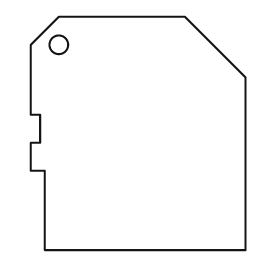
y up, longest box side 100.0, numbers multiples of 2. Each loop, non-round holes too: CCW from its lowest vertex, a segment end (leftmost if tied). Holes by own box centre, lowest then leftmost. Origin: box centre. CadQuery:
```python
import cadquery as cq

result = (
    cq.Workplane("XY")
    .moveTo(-40.0, -50.0)
    .lineTo(46.0, -50.0)
    .lineTo(46.0, 24.0)
    .lineTo(20.0, 50.0)
    .lineTo(-34.0, 50.0)
    .lineTo(-46.0, 38.0)
    .lineTo(-46.0, 8.0)
    .lineTo(-42.0, 8.0)
    .lineTo(-42.0, -4.0)
    .lineTo(-46.0, -4.0)
    .lineTo(-46.0, -16.0)
    .lineTo(-40.0, -16.0)
    .close()
    .moveTo(-34.0, 38.0)
    .circle(4.0)
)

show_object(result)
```